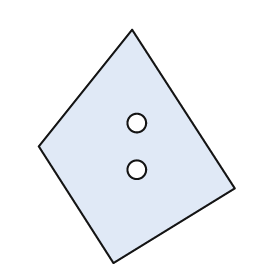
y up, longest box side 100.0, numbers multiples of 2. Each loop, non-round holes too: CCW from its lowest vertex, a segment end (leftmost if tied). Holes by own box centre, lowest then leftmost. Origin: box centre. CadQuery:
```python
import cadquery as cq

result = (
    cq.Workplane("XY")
    .moveTo(-10.0, -50.0)
    .lineTo(42.0, -18.0)
    .lineTo(-2.0, 50.0)
    .lineTo(-42.0, 0.0)
    .close()
    .moveTo(0.0, -10.0)
    .circle(4.0)
    .moveTo(0.0, 10.0)
    .circle(4.0)
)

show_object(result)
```